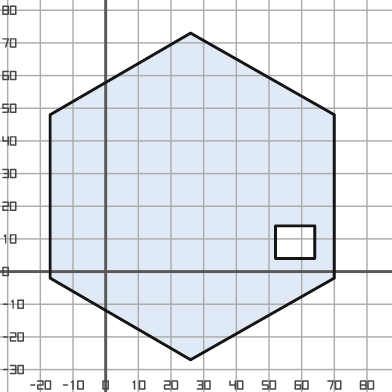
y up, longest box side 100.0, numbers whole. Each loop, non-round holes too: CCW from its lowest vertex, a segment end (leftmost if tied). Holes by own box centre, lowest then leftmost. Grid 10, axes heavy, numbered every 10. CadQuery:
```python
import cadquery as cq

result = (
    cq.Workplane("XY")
    .moveTo(26.0, -27.0)
    .lineTo(70.0, -2.0)
    .lineTo(70.0, 48.0)
    .lineTo(26.0, 73.0)
    .lineTo(-17.0, 48.0)
    .lineTo(-17.0, -2.0)
    .close()
    .moveTo(52.0, 4.0)
    .lineTo(64.0, 4.0)
    .lineTo(64.0, 14.0)
    .lineTo(52.0, 14.0)
    .close()
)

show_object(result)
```